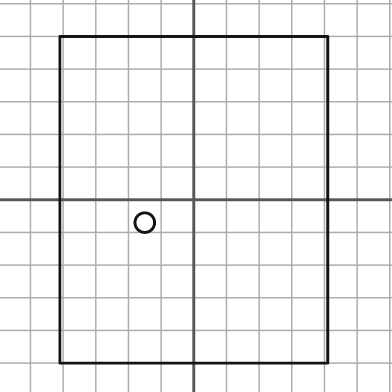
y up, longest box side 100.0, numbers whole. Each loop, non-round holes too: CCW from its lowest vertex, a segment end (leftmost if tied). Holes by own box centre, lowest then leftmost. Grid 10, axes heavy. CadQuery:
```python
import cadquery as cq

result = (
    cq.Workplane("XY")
    .moveTo(-41.0, -50.0)
    .lineTo(41.0, -50.0)
    .lineTo(41.0, 50.0)
    .lineTo(-41.0, 50.0)
    .close()
    .moveTo(-15.0, -7.0)
    .circle(3.0)
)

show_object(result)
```